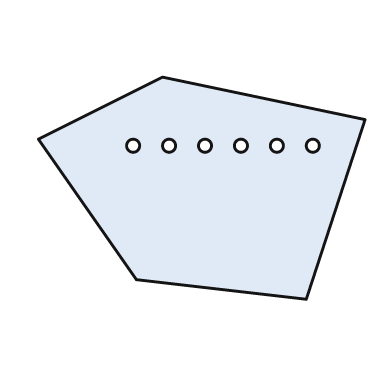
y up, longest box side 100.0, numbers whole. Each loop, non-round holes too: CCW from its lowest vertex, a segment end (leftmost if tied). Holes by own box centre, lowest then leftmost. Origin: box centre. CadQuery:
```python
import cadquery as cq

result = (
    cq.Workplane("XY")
    .moveTo(32.0, -34.0)
    .lineTo(50.0, 21.0)
    .lineTo(-12.0, 34.0)
    .lineTo(-50.0, 15.0)
    .lineTo(-20.0, -28.0)
    .close()
    .moveTo(-21.0, 13.0)
    .circle(2.0)
    .moveTo(-10.0, 13.0)
    .circle(2.0)
    .moveTo(1.0, 13.0)
    .circle(2.0)
    .moveTo(12.0, 13.0)
    .circle(2.0)
    .moveTo(23.0, 13.0)
    .circle(2.0)
    .moveTo(34.0, 13.0)
    .circle(2.0)
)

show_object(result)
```